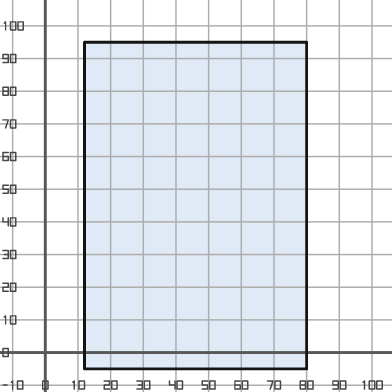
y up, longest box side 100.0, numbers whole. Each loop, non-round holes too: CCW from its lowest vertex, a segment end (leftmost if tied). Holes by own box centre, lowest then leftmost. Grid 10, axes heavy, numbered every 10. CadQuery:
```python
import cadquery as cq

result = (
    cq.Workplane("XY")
    .moveTo(12.0, -5.0)
    .lineTo(80.0, -5.0)
    .lineTo(80.0, 95.0)
    .lineTo(12.0, 95.0)
    .close()
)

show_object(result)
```